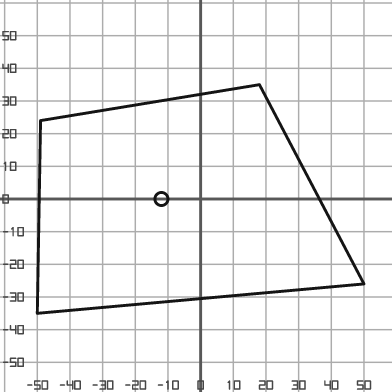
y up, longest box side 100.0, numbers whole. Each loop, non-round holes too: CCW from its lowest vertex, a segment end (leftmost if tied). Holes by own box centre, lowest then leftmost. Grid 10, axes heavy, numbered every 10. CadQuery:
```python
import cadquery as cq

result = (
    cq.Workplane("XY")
    .moveTo(-50.0, -35.0)
    .lineTo(50.0, -26.0)
    .lineTo(18.0, 35.0)
    .lineTo(-49.0, 24.0)
    .close()
    .moveTo(-12.0, 0.0)
    .circle(2.0)
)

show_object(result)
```